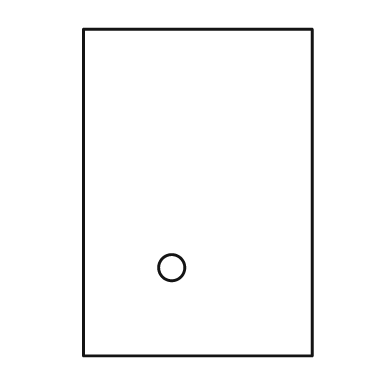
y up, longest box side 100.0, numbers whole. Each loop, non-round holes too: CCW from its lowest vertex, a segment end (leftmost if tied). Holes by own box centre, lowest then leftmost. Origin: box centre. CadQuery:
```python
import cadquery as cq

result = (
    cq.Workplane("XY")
    .moveTo(-35.0, -50.0)
    .lineTo(35.0, -50.0)
    .lineTo(35.0, 50.0)
    .lineTo(-35.0, 50.0)
    .close()
    .moveTo(-8.0, -23.0)
    .circle(4.0)
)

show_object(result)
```